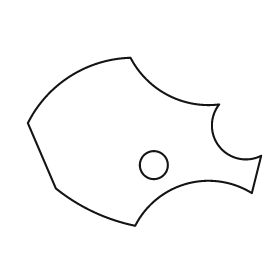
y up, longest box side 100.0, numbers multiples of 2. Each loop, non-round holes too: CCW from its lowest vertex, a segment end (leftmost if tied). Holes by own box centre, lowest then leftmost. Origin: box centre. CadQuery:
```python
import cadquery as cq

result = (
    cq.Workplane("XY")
    .moveTo(-4.0, -36.0)
    .threePointArc((18.0, -18.0), (46.0, -22.0))
    .lineTo(50.0, -6.0)
    .threePointArc((32.0, -2.0), (32.0, 16.0))
    .threePointArc((10.0, 20.0), (-6.0, 36.0))
    .threePointArc((-32.0, 28.0), (-50.0, 8.0))
    .lineTo(-38.0, -20.0)
    .threePointArc((-22.0, -30.0), (-4.0, -36.0))
    .close()
    .moveTo(4.0, -10.0)
    .circle(6.0)
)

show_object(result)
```